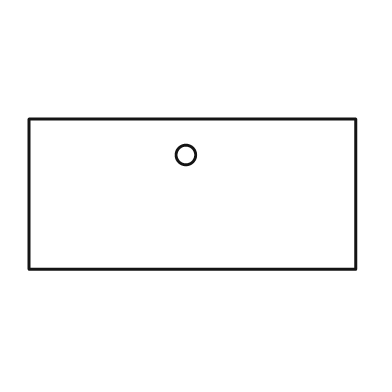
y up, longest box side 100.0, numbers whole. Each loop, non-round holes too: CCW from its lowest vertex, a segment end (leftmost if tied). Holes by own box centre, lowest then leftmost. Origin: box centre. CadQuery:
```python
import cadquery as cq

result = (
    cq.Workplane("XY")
    .moveTo(-50.0, -23.0)
    .lineTo(50.0, -23.0)
    .lineTo(50.0, 23.0)
    .lineTo(-50.0, 23.0)
    .close()
    .moveTo(-2.0, 12.0)
    .circle(3.0)
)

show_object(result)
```